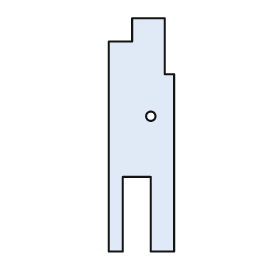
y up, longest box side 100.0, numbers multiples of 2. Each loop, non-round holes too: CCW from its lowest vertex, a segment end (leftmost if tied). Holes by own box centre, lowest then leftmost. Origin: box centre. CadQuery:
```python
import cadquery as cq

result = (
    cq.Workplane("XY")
    .moveTo(-14.0, -50.0)
    .lineTo(-8.0, -50.0)
    .lineTo(-8.0, -18.0)
    .lineTo(4.0, -18.0)
    .lineTo(4.0, -50.0)
    .lineTo(14.0, -50.0)
    .lineTo(14.0, 26.0)
    .lineTo(10.0, 26.0)
    .lineTo(10.0, 50.0)
    .lineTo(-4.0, 50.0)
    .lineTo(-4.0, 40.0)
    .lineTo(-14.0, 40.0)
    .close()
    .moveTo(4.0, 8.0)
    .circle(2.0)
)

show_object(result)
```